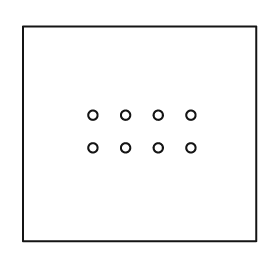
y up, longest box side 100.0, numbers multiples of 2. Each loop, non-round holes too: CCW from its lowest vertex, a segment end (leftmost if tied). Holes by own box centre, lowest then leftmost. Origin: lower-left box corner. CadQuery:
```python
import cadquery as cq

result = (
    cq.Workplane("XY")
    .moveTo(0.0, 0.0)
    .lineTo(100.0, 0.0)
    .lineTo(100.0, 92.0)
    .lineTo(0.0, 92.0)
    .close()
    .moveTo(30.0, 40.0)
    .circle(2.0)
    .moveTo(44.0, 40.0)
    .circle(2.0)
    .moveTo(58.0, 40.0)
    .circle(2.0)
    .moveTo(72.0, 40.0)
    .circle(2.0)
    .moveTo(30.0, 54.0)
    .circle(2.0)
    .moveTo(44.0, 54.0)
    .circle(2.0)
    .moveTo(58.0, 54.0)
    .circle(2.0)
    .moveTo(72.0, 54.0)
    .circle(2.0)
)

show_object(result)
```